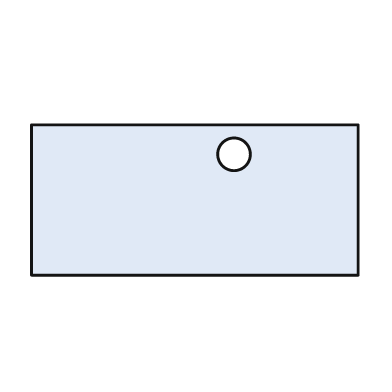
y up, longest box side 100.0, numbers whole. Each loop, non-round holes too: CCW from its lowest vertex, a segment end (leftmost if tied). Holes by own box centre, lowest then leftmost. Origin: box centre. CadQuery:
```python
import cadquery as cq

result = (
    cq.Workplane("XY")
    .moveTo(-50.0, -23.0)
    .lineTo(50.0, -23.0)
    .lineTo(50.0, 23.0)
    .lineTo(-50.0, 23.0)
    .close()
    .moveTo(12.0, 14.0)
    .circle(5.0)
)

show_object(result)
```